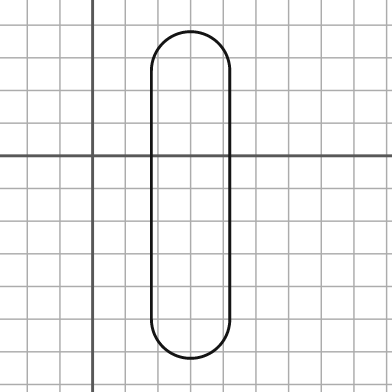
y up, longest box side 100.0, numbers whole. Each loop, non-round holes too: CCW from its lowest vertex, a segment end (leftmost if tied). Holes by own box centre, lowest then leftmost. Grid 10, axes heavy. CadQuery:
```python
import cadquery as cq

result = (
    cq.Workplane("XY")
    .moveTo(18.0, -50.0)
    .threePointArc((30.0, -62.0), (42.0, -50.0))
    .lineTo(42.0, 26.0)
    .threePointArc((30.0, 38.0), (18.0, 26.0))
    .close()
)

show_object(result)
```